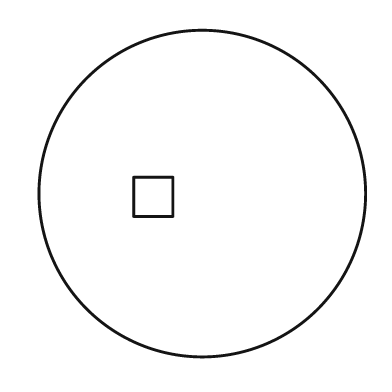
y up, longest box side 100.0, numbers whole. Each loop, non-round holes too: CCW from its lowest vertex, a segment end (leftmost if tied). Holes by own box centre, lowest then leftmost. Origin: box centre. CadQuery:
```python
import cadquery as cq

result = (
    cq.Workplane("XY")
    .moveTo(0.0, 0.0)
    .circle(50.0)
    .moveTo(-21.0, -7.0)
    .lineTo(-9.0, -7.0)
    .lineTo(-9.0, 5.0)
    .lineTo(-21.0, 5.0)
    .close()
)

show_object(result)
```